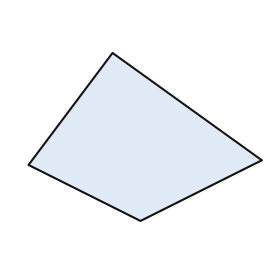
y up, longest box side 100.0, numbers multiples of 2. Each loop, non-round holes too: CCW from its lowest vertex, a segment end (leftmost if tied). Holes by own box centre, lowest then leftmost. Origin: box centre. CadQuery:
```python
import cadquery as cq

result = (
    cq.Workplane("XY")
    .moveTo(-2.0, -36.0)
    .lineTo(50.0, -10.0)
    .lineTo(-14.0, 36.0)
    .lineTo(-50.0, -12.0)
    .close()
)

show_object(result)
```